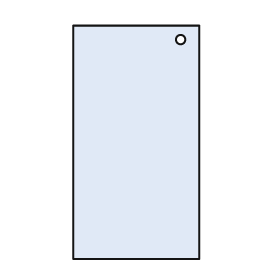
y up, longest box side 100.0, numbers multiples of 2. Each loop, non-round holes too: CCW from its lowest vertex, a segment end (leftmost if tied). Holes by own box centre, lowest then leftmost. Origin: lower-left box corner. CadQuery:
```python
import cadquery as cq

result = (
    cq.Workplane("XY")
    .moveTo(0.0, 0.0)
    .lineTo(54.0, 0.0)
    .lineTo(54.0, 100.0)
    .lineTo(0.0, 100.0)
    .close()
    .moveTo(46.0, 94.0)
    .circle(2.0)
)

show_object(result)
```